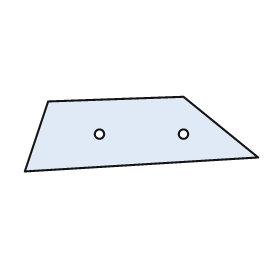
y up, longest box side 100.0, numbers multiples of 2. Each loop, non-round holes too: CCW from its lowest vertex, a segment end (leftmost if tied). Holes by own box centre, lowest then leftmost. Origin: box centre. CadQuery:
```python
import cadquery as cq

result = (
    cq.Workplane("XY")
    .moveTo(-50.0, -16.0)
    .lineTo(50.0, -10.0)
    .lineTo(18.0, 16.0)
    .lineTo(-40.0, 14.0)
    .close()
    .moveTo(-18.0, 0.0)
    .circle(2.0)
    .moveTo(18.0, 0.0)
    .circle(2.0)
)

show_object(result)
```